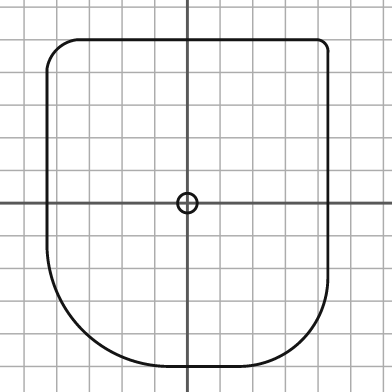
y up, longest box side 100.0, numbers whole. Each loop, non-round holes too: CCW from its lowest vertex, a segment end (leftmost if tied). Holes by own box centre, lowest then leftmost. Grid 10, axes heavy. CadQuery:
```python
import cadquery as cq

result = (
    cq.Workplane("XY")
    .moveTo(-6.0, -50.0)
    .lineTo(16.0, -50.0)
    .threePointArc((35.0, -42.0), (43.0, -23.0))
    .lineTo(43.0, 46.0)
    .threePointArc((42.0, 49.0), (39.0, 50.0))
    .lineTo(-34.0, 50.0)
    .threePointArc((-40.0, 47.0), (-43.0, 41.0))
    .lineTo(-43.0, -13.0)
    .threePointArc((-32.0, -39.0), (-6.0, -50.0))
    .close()
    .moveTo(0.0, 0.0)
    .circle(3.0)
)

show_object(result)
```